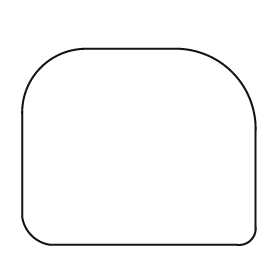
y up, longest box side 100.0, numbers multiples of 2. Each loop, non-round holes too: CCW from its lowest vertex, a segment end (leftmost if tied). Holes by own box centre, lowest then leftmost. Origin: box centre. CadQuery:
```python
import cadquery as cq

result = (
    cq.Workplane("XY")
    .moveTo(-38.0, -42.0)
    .lineTo(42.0, -42.0)
    .threePointArc((48.0, -40.0), (50.0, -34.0))
    .lineTo(50.0, 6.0)
    .threePointArc((40.0, 32.0), (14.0, 42.0))
    .lineTo(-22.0, 42.0)
    .threePointArc((-42.0, 34.0), (-50.0, 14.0))
    .lineTo(-50.0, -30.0)
    .threePointArc((-46.0, -38.0), (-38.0, -42.0))
    .close()
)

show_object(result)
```